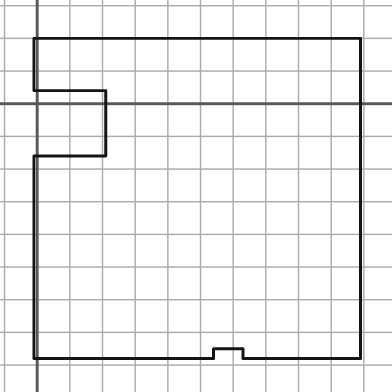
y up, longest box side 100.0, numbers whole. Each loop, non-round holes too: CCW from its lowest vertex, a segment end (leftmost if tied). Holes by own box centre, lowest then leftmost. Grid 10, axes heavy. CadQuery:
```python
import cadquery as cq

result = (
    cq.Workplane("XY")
    .moveTo(-1.0, -78.0)
    .lineTo(54.0, -78.0)
    .lineTo(54.0, -75.0)
    .lineTo(63.0, -75.0)
    .lineTo(63.0, -78.0)
    .lineTo(99.0, -78.0)
    .lineTo(99.0, 20.0)
    .lineTo(-1.0, 20.0)
    .lineTo(-1.0, 4.0)
    .lineTo(21.0, 4.0)
    .lineTo(21.0, -16.0)
    .lineTo(-1.0, -16.0)
    .close()
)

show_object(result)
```